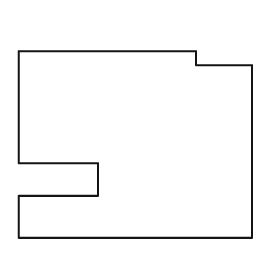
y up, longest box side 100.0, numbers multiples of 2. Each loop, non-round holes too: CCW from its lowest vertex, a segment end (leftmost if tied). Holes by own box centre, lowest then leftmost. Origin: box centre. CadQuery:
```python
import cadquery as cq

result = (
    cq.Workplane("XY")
    .moveTo(-50.0, -40.0)
    .lineTo(50.0, -40.0)
    .lineTo(50.0, 34.0)
    .lineTo(26.0, 34.0)
    .lineTo(26.0, 40.0)
    .lineTo(-50.0, 40.0)
    .lineTo(-50.0, -8.0)
    .lineTo(-16.0, -8.0)
    .lineTo(-16.0, -22.0)
    .lineTo(-50.0, -22.0)
    .close()
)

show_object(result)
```